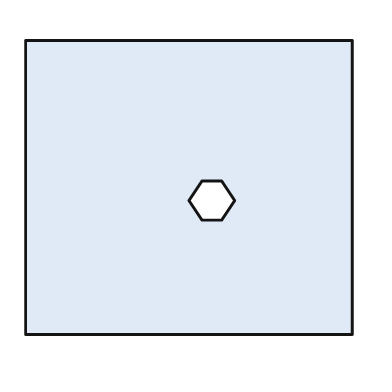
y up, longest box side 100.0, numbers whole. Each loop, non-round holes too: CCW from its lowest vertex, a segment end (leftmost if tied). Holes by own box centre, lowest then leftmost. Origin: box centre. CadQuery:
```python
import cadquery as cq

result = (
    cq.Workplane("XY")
    .moveTo(-50.0, -45.0)
    .lineTo(50.0, -45.0)
    .lineTo(50.0, 45.0)
    .lineTo(-50.0, 45.0)
    .close()
    .moveTo(4.0, -10.0)
    .lineTo(10.0, -10.0)
    .lineTo(14.0, -4.0)
    .lineTo(10.0, 2.0)
    .lineTo(4.0, 2.0)
    .lineTo(0.0, -4.0)
    .close()
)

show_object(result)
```